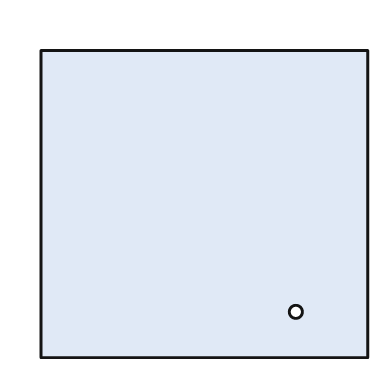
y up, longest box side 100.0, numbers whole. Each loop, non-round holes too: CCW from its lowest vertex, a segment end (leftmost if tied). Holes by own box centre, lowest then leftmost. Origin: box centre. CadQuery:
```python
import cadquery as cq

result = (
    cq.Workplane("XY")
    .moveTo(-50.0, -47.0)
    .lineTo(50.0, -47.0)
    .lineTo(50.0, 47.0)
    .lineTo(-50.0, 47.0)
    .close()
    .moveTo(28.0, -33.0)
    .circle(2.0)
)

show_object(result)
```